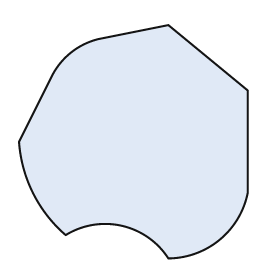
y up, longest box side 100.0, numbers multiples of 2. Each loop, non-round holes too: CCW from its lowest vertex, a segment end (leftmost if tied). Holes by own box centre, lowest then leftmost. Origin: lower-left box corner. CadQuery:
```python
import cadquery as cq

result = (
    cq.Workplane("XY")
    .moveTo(64.0, 0.0)
    .threePointArc((86.0, 8.0), (98.0, 28.0))
    .lineTo(98.0, 72.0)
    .lineTo(64.0, 100.0)
    .lineTo(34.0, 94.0)
    .threePointArc((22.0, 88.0), (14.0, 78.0))
    .lineTo(0.0, 50.0)
    .threePointArc((6.0, 28.0), (20.0, 10.0))
    .threePointArc((44.0, 14.0), (64.0, 0.0))
    .close()
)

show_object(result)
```